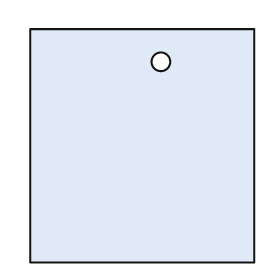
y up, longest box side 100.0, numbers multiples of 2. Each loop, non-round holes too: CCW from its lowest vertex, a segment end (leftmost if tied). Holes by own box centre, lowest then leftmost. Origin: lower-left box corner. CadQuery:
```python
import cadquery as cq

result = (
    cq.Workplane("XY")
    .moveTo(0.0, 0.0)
    .lineTo(96.0, 0.0)
    .lineTo(96.0, 100.0)
    .lineTo(0.0, 100.0)
    .close()
    .moveTo(56.0, 86.0)
    .circle(4.0)
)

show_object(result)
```